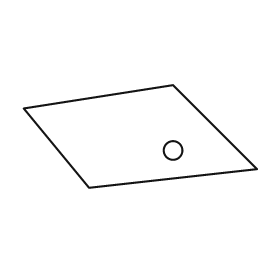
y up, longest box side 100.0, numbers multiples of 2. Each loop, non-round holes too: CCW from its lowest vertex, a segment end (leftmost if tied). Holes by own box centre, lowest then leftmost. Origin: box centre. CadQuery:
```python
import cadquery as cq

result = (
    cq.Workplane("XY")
    .moveTo(-22.0, -22.0)
    .lineTo(50.0, -14.0)
    .lineTo(14.0, 22.0)
    .lineTo(-50.0, 12.0)
    .close()
    .moveTo(14.0, -6.0)
    .circle(4.0)
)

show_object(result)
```